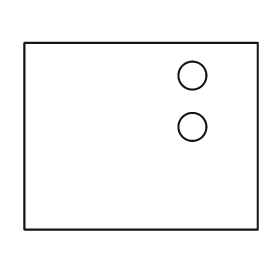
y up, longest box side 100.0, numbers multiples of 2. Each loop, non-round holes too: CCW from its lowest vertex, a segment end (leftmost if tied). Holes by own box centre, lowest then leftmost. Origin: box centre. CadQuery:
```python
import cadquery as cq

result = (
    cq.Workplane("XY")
    .moveTo(-50.0, -40.0)
    .lineTo(50.0, -40.0)
    .lineTo(50.0, 40.0)
    .lineTo(-50.0, 40.0)
    .close()
    .moveTo(22.0, 4.0)
    .circle(6.0)
    .moveTo(22.0, 26.0)
    .circle(6.0)
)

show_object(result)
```